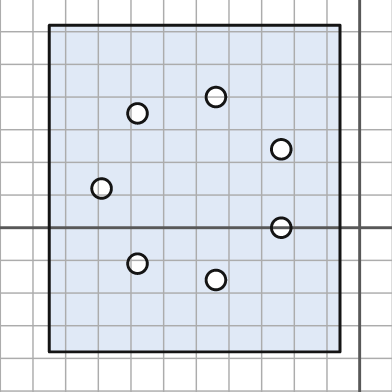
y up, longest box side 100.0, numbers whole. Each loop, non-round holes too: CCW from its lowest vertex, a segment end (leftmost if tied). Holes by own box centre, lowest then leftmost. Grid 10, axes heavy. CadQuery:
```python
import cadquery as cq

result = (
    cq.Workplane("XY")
    .moveTo(-95.0, -38.0)
    .lineTo(-6.0, -38.0)
    .lineTo(-6.0, 62.0)
    .lineTo(-95.0, 62.0)
    .close()
    .moveTo(-44.0, -16.0)
    .circle(3.0)
    .moveTo(-68.0, -11.0)
    .circle(3.0)
    .moveTo(-24.0, 0.0)
    .circle(3.0)
    .moveTo(-79.0, 12.0)
    .circle(3.0)
    .moveTo(-24.0, 24.0)
    .circle(3.0)
    .moveTo(-68.0, 35.0)
    .circle(3.0)
    .moveTo(-44.0, 40.0)
    .circle(3.0)
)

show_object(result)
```